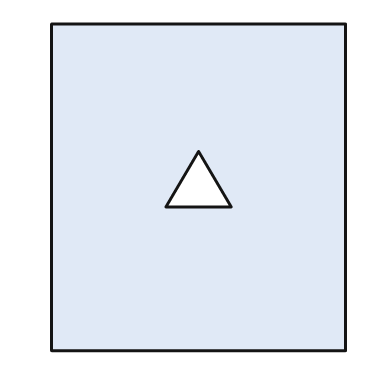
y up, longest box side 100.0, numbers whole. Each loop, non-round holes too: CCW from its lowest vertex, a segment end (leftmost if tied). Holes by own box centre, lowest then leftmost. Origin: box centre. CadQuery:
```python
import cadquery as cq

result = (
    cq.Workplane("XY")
    .moveTo(-45.0, -50.0)
    .lineTo(45.0, -50.0)
    .lineTo(45.0, 50.0)
    .lineTo(-45.0, 50.0)
    .close()
    .moveTo(-10.0, -6.0)
    .lineTo(10.0, -6.0)
    .lineTo(0.0, 11.0)
    .close()
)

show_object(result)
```